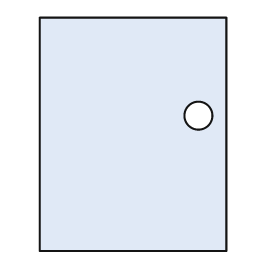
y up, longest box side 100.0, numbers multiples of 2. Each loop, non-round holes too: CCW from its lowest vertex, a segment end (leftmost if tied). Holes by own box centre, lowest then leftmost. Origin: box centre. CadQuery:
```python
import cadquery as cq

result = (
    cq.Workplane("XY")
    .moveTo(-40.0, -50.0)
    .lineTo(40.0, -50.0)
    .lineTo(40.0, 50.0)
    .lineTo(-40.0, 50.0)
    .close()
    .moveTo(28.0, 8.0)
    .circle(6.0)
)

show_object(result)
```